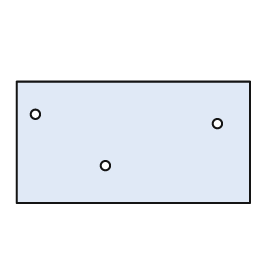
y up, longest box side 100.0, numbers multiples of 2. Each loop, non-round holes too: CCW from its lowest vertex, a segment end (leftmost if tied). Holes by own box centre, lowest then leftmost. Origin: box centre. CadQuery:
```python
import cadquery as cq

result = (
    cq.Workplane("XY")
    .moveTo(-50.0, -26.0)
    .lineTo(50.0, -26.0)
    .lineTo(50.0, 26.0)
    .lineTo(-50.0, 26.0)
    .close()
    .moveTo(-12.0, -10.0)
    .circle(2.0)
    .moveTo(36.0, 8.0)
    .circle(2.0)
    .moveTo(-42.0, 12.0)
    .circle(2.0)
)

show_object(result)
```